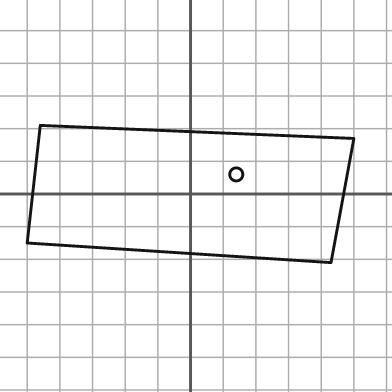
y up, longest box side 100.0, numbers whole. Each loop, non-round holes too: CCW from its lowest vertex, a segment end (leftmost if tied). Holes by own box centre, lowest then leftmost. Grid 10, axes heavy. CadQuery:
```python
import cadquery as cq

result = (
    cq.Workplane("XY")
    .moveTo(43.0, -21.0)
    .lineTo(50.0, 17.0)
    .lineTo(-46.0, 21.0)
    .lineTo(-50.0, -15.0)
    .close()
    .moveTo(14.0, 6.0)
    .circle(2.0)
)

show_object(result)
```